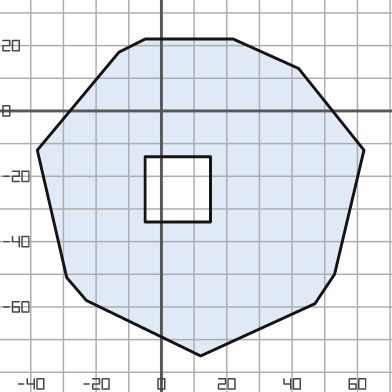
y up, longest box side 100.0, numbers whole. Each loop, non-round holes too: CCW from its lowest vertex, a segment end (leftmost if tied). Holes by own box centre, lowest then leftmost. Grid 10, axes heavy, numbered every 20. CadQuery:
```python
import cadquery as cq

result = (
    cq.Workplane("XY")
    .moveTo(12.0, -75.0)
    .lineTo(47.0, -59.0)
    .lineTo(53.0, -50.0)
    .lineTo(62.0, -12.0)
    .lineTo(42.0, 13.0)
    .lineTo(22.0, 22.0)
    .lineTo(-5.0, 22.0)
    .lineTo(-13.0, 18.0)
    .lineTo(-38.0, -12.0)
    .lineTo(-29.0, -51.0)
    .lineTo(-23.0, -58.0)
    .close()
    .moveTo(-5.0, -34.0)
    .lineTo(15.0, -34.0)
    .lineTo(15.0, -14.0)
    .lineTo(-5.0, -14.0)
    .close()
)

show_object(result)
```